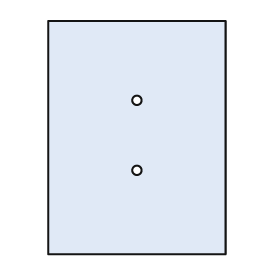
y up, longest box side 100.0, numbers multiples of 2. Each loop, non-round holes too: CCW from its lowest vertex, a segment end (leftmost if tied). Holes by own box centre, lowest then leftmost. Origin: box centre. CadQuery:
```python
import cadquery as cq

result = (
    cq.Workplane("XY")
    .moveTo(-38.0, -50.0)
    .lineTo(38.0, -50.0)
    .lineTo(38.0, 50.0)
    .lineTo(-38.0, 50.0)
    .close()
    .moveTo(0.0, -14.0)
    .circle(2.0)
    .moveTo(0.0, 16.0)
    .circle(2.0)
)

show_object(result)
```